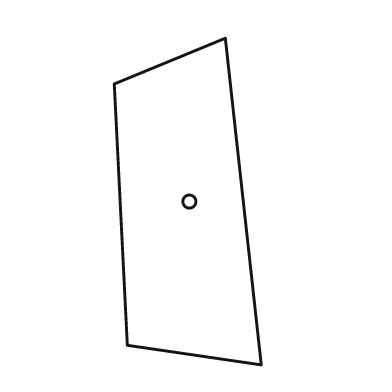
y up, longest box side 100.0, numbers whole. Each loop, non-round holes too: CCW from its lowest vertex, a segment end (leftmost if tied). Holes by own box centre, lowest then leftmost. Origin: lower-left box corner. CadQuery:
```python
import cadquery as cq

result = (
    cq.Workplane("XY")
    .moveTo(45.0, 0.0)
    .lineTo(34.0, 100.0)
    .lineTo(0.0, 86.0)
    .lineTo(4.0, 6.0)
    .close()
    .moveTo(23.0, 50.0)
    .circle(2.0)
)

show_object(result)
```